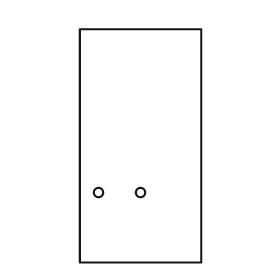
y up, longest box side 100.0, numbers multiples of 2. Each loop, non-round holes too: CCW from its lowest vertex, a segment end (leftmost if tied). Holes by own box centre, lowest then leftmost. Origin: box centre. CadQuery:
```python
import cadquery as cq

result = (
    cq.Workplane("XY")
    .moveTo(-26.0, -50.0)
    .lineTo(26.0, -50.0)
    .lineTo(26.0, 50.0)
    .lineTo(-26.0, 50.0)
    .close()
    .moveTo(-18.0, -20.0)
    .circle(2.0)
    .moveTo(0.0, -20.0)
    .circle(2.0)
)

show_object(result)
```